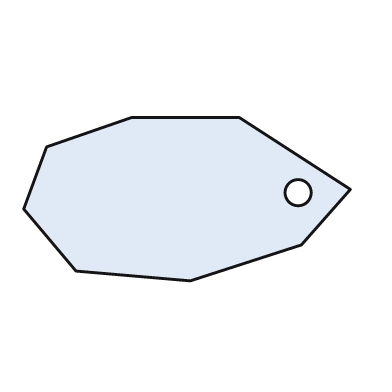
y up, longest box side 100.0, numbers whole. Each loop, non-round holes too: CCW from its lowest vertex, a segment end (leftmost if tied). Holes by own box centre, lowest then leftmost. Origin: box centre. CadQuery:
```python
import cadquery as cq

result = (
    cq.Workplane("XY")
    .moveTo(1.0, -25.0)
    .lineTo(35.0, -14.0)
    .lineTo(50.0, 3.0)
    .lineTo(16.0, 25.0)
    .lineTo(-17.0, 25.0)
    .lineTo(-43.0, 16.0)
    .lineTo(-50.0, -3.0)
    .lineTo(-34.0, -22.0)
    .close()
    .moveTo(34.0, 2.0)
    .circle(4.0)
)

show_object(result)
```